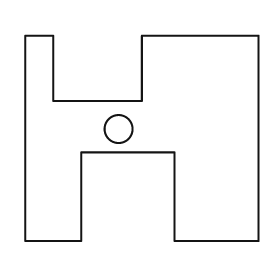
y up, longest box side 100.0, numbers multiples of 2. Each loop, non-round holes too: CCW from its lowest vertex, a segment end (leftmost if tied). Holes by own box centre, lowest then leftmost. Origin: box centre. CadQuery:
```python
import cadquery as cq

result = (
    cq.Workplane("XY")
    .moveTo(-50.0, -44.0)
    .lineTo(-26.0, -44.0)
    .lineTo(-26.0, -6.0)
    .lineTo(14.0, -6.0)
    .lineTo(14.0, -44.0)
    .lineTo(50.0, -44.0)
    .lineTo(50.0, 44.0)
    .lineTo(0.0, 44.0)
    .lineTo(0.0, 16.0)
    .lineTo(-38.0, 16.0)
    .lineTo(-38.0, 44.0)
    .lineTo(-50.0, 44.0)
    .close()
    .moveTo(-10.0, 4.0)
    .circle(6.0)
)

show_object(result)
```